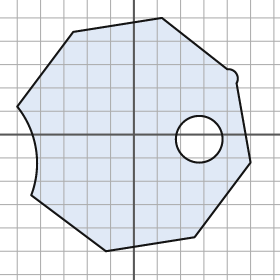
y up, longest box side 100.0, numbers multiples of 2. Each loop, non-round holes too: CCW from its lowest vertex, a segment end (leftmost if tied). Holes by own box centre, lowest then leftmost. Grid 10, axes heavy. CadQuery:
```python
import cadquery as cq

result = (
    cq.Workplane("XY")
    .moveTo(-12.0, -50.0)
    .lineTo(26.0, -44.0)
    .lineTo(50.0, -12.0)
    .lineTo(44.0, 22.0)
    .threePointArc((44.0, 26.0), (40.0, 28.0))
    .lineTo(12.0, 50.0)
    .lineTo(-26.0, 44.0)
    .lineTo(-50.0, 12.0)
    .threePointArc((-42.0, -6.0), (-44.0, -26.0))
    .close()
    .moveTo(28.0, -2.0)
    .circle(10.0)
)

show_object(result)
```